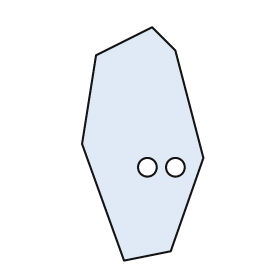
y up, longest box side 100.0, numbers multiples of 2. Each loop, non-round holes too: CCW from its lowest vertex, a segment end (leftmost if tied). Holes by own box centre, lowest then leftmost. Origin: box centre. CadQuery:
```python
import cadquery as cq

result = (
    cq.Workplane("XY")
    .moveTo(-8.0, -50.0)
    .lineTo(12.0, -46.0)
    .lineTo(26.0, -6.0)
    .lineTo(14.0, 40.0)
    .lineTo(4.0, 50.0)
    .lineTo(-20.0, 38.0)
    .lineTo(-26.0, 0.0)
    .close()
    .moveTo(2.0, -10.0)
    .circle(4.0)
    .moveTo(14.0, -10.0)
    .circle(4.0)
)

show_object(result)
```